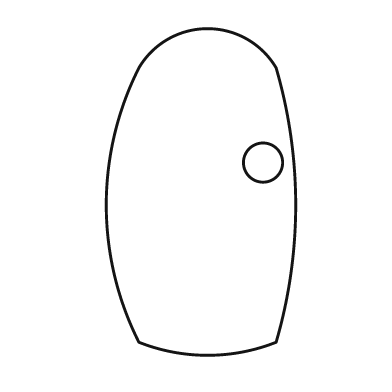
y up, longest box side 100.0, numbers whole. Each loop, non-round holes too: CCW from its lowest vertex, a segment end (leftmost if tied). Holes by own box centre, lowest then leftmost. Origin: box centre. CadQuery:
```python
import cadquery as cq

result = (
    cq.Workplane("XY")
    .moveTo(-19.0, -46.0)
    .threePointArc((2.0, -50.0), (23.0, -46.0))
    .threePointArc((29.0, -4.0), (23.0, 38.0))
    .threePointArc((2.0, 50.0), (-19.0, 38.0))
    .threePointArc((-29.0, -4.0), (-19.0, -46.0))
    .close()
    .moveTo(19.0, 9.0)
    .circle(6.0)
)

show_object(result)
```